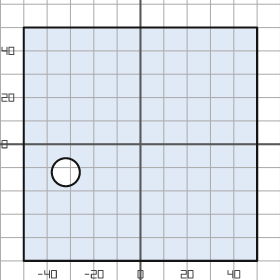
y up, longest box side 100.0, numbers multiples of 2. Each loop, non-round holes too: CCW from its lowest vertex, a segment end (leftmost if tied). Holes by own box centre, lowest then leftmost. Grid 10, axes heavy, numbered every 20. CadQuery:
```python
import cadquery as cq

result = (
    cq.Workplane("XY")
    .moveTo(-50.0, -50.0)
    .lineTo(50.0, -50.0)
    .lineTo(50.0, 50.0)
    .lineTo(-50.0, 50.0)
    .close()
    .moveTo(-32.0, -12.0)
    .circle(6.0)
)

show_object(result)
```